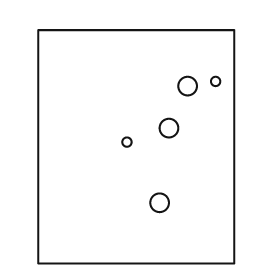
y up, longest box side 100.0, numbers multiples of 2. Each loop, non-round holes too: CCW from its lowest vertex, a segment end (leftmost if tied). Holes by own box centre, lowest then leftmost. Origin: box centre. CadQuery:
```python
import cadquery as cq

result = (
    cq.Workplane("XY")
    .moveTo(-42.0, -50.0)
    .lineTo(42.0, -50.0)
    .lineTo(42.0, 50.0)
    .lineTo(-42.0, 50.0)
    .close()
    .moveTo(10.0, -24.0)
    .circle(4.0)
    .moveTo(-4.0, 2.0)
    .circle(2.0)
    .moveTo(14.0, 8.0)
    .circle(4.0)
    .moveTo(22.0, 26.0)
    .circle(4.0)
    .moveTo(34.0, 28.0)
    .circle(2.0)
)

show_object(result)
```